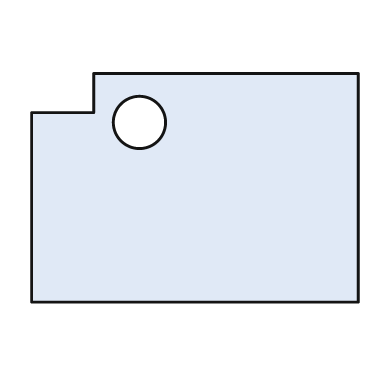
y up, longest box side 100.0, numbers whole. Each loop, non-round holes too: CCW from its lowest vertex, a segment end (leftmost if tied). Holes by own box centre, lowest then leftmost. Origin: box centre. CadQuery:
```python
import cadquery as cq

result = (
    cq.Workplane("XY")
    .moveTo(-50.0, -35.0)
    .lineTo(50.0, -35.0)
    .lineTo(50.0, 35.0)
    .lineTo(-31.0, 35.0)
    .lineTo(-31.0, 23.0)
    .lineTo(-50.0, 23.0)
    .close()
    .moveTo(-17.0, 20.0)
    .circle(8.0)
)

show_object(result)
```